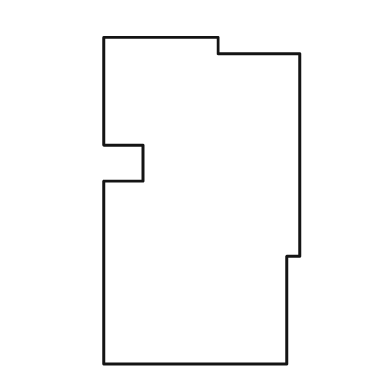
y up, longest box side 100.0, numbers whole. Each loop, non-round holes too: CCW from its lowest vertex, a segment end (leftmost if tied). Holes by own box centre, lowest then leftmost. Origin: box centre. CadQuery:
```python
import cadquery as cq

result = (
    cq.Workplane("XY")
    .moveTo(-30.0, -50.0)
    .lineTo(26.0, -50.0)
    .lineTo(26.0, -17.0)
    .lineTo(30.0, -17.0)
    .lineTo(30.0, 45.0)
    .lineTo(5.0, 45.0)
    .lineTo(5.0, 50.0)
    .lineTo(-30.0, 50.0)
    .lineTo(-30.0, 17.0)
    .lineTo(-18.0, 17.0)
    .lineTo(-18.0, 6.0)
    .lineTo(-30.0, 6.0)
    .close()
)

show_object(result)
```